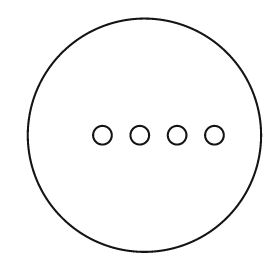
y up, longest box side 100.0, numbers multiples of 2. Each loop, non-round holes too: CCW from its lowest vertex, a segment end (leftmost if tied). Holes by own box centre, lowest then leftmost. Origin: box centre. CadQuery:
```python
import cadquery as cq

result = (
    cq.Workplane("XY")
    .moveTo(0.0, 0.0)
    .circle(50.0)
    .moveTo(-18.0, 0.0)
    .circle(4.0)
    .moveTo(-2.0, 0.0)
    .circle(4.0)
    .moveTo(14.0, 0.0)
    .circle(4.0)
    .moveTo(30.0, 0.0)
    .circle(4.0)
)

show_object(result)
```